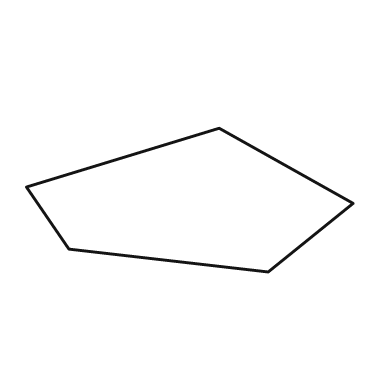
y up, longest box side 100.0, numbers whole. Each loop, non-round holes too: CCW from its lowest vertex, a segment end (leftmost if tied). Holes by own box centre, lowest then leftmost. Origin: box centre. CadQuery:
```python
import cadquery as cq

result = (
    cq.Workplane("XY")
    .moveTo(24.0, -22.0)
    .lineTo(50.0, -1.0)
    .lineTo(9.0, 22.0)
    .lineTo(-50.0, 4.0)
    .lineTo(-37.0, -15.0)
    .close()
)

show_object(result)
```